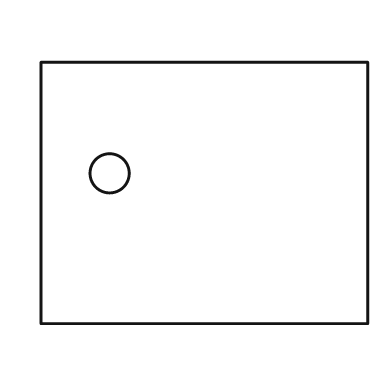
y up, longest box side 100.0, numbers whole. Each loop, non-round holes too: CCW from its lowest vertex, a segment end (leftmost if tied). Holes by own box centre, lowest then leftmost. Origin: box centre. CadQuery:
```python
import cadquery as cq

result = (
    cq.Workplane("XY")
    .moveTo(-50.0, -40.0)
    .lineTo(50.0, -40.0)
    .lineTo(50.0, 40.0)
    .lineTo(-50.0, 40.0)
    .close()
    .moveTo(-29.0, 6.0)
    .circle(6.0)
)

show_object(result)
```